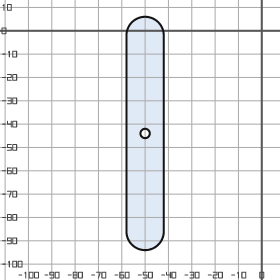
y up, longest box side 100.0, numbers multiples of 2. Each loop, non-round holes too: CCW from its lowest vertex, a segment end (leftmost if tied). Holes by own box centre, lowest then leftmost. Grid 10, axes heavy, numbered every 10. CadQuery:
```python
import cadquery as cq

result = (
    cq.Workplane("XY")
    .moveTo(-58.0, -86.0)
    .threePointArc((-50.0, -94.0), (-42.0, -86.0))
    .lineTo(-42.0, -2.0)
    .threePointArc((-50.0, 6.0), (-58.0, -2.0))
    .close()
    .moveTo(-50.0, -44.0)
    .circle(2.0)
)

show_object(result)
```